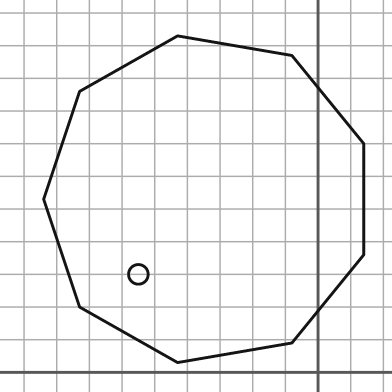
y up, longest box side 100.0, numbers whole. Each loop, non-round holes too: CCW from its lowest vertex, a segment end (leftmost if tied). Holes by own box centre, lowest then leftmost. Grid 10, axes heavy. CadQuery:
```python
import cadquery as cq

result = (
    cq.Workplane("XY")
    .moveTo(-43.0, 3.0)
    .lineTo(-8.0, 9.0)
    .lineTo(14.0, 36.0)
    .lineTo(14.0, 70.0)
    .lineTo(-8.0, 97.0)
    .lineTo(-43.0, 103.0)
    .lineTo(-73.0, 86.0)
    .lineTo(-84.0, 53.0)
    .lineTo(-73.0, 20.0)
    .close()
    .moveTo(-55.0, 30.0)
    .circle(3.0)
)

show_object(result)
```